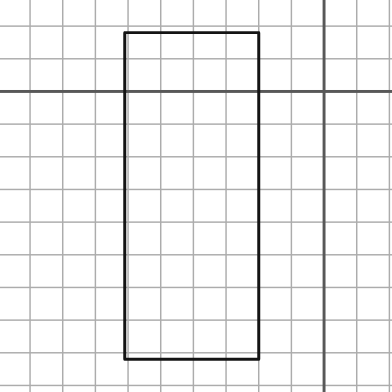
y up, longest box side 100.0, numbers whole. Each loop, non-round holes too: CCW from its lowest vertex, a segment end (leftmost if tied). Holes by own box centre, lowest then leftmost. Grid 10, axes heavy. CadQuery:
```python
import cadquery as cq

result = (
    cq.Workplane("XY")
    .moveTo(-61.0, -82.0)
    .lineTo(-20.0, -82.0)
    .lineTo(-20.0, 18.0)
    .lineTo(-61.0, 18.0)
    .close()
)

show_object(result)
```